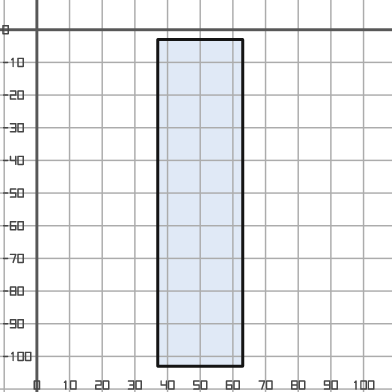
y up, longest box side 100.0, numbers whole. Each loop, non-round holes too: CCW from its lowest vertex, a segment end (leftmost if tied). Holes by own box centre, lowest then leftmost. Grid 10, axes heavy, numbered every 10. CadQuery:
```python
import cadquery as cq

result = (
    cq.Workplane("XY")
    .moveTo(37.0, -103.0)
    .lineTo(63.0, -103.0)
    .lineTo(63.0, -3.0)
    .lineTo(37.0, -3.0)
    .close()
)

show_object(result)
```